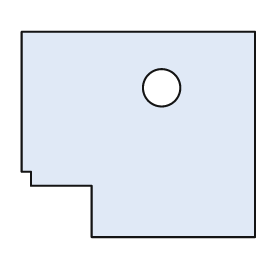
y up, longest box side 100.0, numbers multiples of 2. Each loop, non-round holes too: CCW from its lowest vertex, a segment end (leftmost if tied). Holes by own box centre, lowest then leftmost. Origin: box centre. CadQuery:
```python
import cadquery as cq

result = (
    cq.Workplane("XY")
    .moveTo(-20.0, -44.0)
    .lineTo(50.0, -44.0)
    .lineTo(50.0, 44.0)
    .lineTo(-50.0, 44.0)
    .lineTo(-50.0, -16.0)
    .lineTo(-46.0, -16.0)
    .lineTo(-46.0, -22.0)
    .lineTo(-20.0, -22.0)
    .close()
    .moveTo(10.0, 20.0)
    .circle(8.0)
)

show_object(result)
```